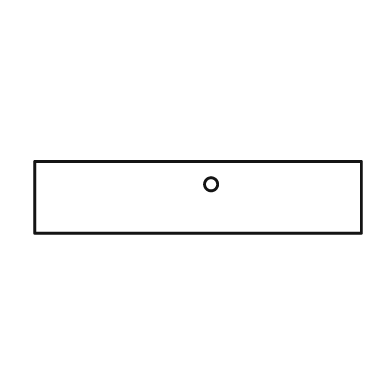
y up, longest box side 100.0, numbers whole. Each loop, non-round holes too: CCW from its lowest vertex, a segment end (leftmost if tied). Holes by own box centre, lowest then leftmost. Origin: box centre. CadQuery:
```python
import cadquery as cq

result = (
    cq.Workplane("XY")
    .moveTo(-50.0, -11.0)
    .lineTo(50.0, -11.0)
    .lineTo(50.0, 11.0)
    .lineTo(-50.0, 11.0)
    .close()
    .moveTo(4.0, 4.0)
    .circle(2.0)
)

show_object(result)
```